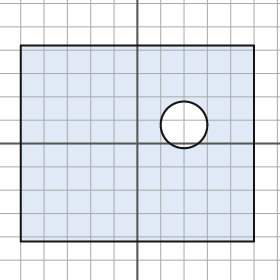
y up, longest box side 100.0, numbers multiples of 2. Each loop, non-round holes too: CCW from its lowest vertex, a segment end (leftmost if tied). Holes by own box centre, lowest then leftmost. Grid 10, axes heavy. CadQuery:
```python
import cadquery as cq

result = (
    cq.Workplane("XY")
    .moveTo(-50.0, -42.0)
    .lineTo(50.0, -42.0)
    .lineTo(50.0, 42.0)
    .lineTo(-50.0, 42.0)
    .close()
    .moveTo(20.0, 8.0)
    .circle(10.0)
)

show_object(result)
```